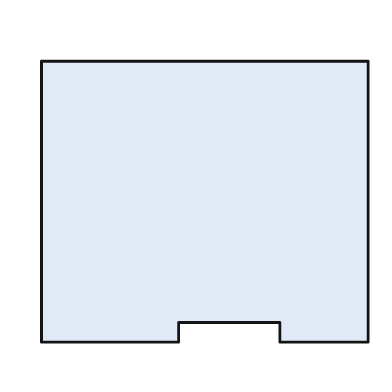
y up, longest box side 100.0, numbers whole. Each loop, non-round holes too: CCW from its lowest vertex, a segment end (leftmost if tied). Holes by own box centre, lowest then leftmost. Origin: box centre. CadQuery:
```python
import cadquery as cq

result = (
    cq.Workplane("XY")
    .moveTo(-50.0, -43.0)
    .lineTo(-8.0, -43.0)
    .lineTo(-8.0, -37.0)
    .lineTo(23.0, -37.0)
    .lineTo(23.0, -43.0)
    .lineTo(50.0, -43.0)
    .lineTo(50.0, 43.0)
    .lineTo(-50.0, 43.0)
    .close()
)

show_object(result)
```